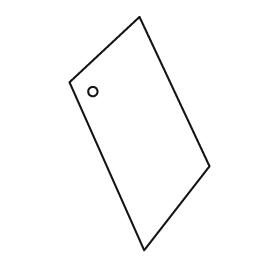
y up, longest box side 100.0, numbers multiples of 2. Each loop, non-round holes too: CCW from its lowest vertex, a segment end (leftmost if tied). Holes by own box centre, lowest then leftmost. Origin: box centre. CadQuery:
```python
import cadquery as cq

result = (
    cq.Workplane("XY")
    .moveTo(2.0, -50.0)
    .lineTo(30.0, -14.0)
    .lineTo(0.0, 50.0)
    .lineTo(-30.0, 22.0)
    .close()
    .moveTo(-20.0, 18.0)
    .circle(2.0)
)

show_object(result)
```